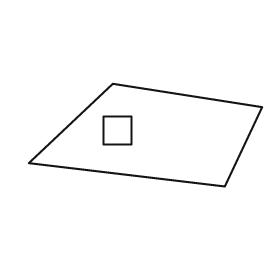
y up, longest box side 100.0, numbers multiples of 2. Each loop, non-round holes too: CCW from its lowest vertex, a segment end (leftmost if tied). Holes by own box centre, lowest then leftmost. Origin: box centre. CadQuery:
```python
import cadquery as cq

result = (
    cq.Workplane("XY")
    .moveTo(34.0, -22.0)
    .lineTo(50.0, 12.0)
    .lineTo(-14.0, 22.0)
    .lineTo(-50.0, -12.0)
    .close()
    .moveTo(-18.0, -4.0)
    .lineTo(-6.0, -4.0)
    .lineTo(-6.0, 8.0)
    .lineTo(-18.0, 8.0)
    .close()
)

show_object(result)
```